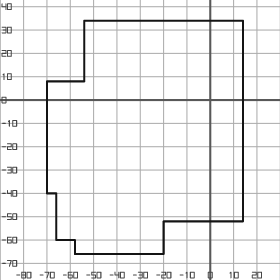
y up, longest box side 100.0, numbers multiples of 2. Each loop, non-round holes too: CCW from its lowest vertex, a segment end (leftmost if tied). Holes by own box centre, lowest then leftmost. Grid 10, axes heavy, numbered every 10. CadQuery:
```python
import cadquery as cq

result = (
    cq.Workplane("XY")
    .moveTo(-58.0, -66.0)
    .lineTo(-20.0, -66.0)
    .lineTo(-20.0, -52.0)
    .lineTo(14.0, -52.0)
    .lineTo(14.0, 34.0)
    .lineTo(-54.0, 34.0)
    .lineTo(-54.0, 8.0)
    .lineTo(-70.0, 8.0)
    .lineTo(-70.0, -40.0)
    .lineTo(-66.0, -40.0)
    .lineTo(-66.0, -60.0)
    .lineTo(-58.0, -60.0)
    .close()
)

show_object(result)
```